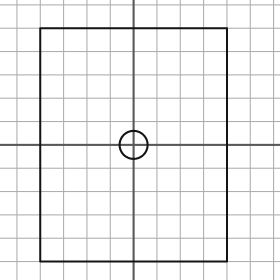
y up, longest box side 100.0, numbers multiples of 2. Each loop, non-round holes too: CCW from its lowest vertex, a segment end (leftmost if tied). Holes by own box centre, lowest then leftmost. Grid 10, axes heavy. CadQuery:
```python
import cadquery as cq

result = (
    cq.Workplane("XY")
    .moveTo(-40.0, -50.0)
    .lineTo(40.0, -50.0)
    .lineTo(40.0, 50.0)
    .lineTo(-40.0, 50.0)
    .close()
    .moveTo(0.0, 0.0)
    .circle(6.0)
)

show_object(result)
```